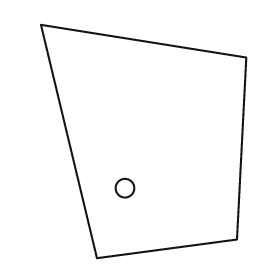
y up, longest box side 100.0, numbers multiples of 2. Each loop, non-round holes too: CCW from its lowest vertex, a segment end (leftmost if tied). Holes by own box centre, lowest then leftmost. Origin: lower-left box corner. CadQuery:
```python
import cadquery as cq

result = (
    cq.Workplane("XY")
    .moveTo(24.0, 0.0)
    .lineTo(84.0, 8.0)
    .lineTo(88.0, 86.0)
    .lineTo(0.0, 100.0)
    .close()
    .moveTo(36.0, 30.0)
    .circle(4.0)
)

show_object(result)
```